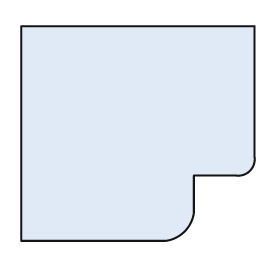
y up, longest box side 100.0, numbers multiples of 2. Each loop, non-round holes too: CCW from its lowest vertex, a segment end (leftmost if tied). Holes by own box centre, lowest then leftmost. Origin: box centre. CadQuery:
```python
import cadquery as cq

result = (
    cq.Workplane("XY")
    .moveTo(-50.0, -46.0)
    .lineTo(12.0, -46.0)
    .threePointArc((20.0, -42.0), (24.0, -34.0))
    .lineTo(24.0, -18.0)
    .lineTo(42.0, -18.0)
    .threePointArc((48.0, -16.0), (50.0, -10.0))
    .lineTo(50.0, 46.0)
    .lineTo(-50.0, 46.0)
    .close()
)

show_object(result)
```